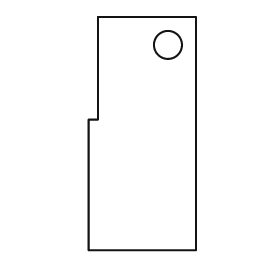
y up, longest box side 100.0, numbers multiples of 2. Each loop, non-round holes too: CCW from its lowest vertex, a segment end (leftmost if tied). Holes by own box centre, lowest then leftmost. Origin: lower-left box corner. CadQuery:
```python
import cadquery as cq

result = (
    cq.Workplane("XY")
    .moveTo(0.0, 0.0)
    .lineTo(46.0, 0.0)
    .lineTo(46.0, 100.0)
    .lineTo(4.0, 100.0)
    .lineTo(4.0, 56.0)
    .lineTo(0.0, 56.0)
    .close()
    .moveTo(34.0, 88.0)
    .circle(6.0)
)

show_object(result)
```